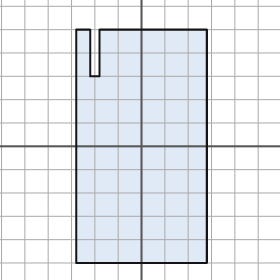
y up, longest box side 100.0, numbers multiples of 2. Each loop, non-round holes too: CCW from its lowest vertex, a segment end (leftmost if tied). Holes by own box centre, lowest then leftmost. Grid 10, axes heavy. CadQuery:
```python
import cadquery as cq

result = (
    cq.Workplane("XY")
    .moveTo(-28.0, -50.0)
    .lineTo(28.0, -50.0)
    .lineTo(28.0, 50.0)
    .lineTo(-18.0, 50.0)
    .lineTo(-18.0, 30.0)
    .lineTo(-22.0, 30.0)
    .lineTo(-22.0, 50.0)
    .lineTo(-28.0, 50.0)
    .close()
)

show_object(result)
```